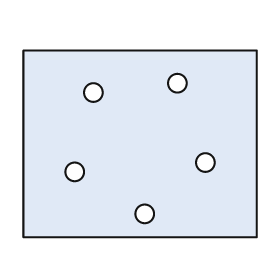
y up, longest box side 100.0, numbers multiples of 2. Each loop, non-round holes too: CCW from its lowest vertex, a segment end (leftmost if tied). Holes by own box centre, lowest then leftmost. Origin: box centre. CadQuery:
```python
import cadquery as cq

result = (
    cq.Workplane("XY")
    .moveTo(-50.0, -40.0)
    .lineTo(50.0, -40.0)
    .lineTo(50.0, 40.0)
    .lineTo(-50.0, 40.0)
    .close()
    .moveTo(2.0, -30.0)
    .circle(4.0)
    .moveTo(-28.0, -12.0)
    .circle(4.0)
    .moveTo(28.0, -8.0)
    .circle(4.0)
    .moveTo(-20.0, 22.0)
    .circle(4.0)
    .moveTo(16.0, 26.0)
    .circle(4.0)
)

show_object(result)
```